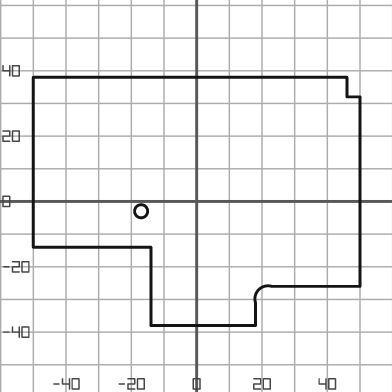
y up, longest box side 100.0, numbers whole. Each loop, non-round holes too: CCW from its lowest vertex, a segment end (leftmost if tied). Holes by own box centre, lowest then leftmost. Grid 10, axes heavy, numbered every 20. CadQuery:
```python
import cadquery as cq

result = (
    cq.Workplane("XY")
    .moveTo(-14.0, -38.0)
    .lineTo(18.0, -38.0)
    .lineTo(18.0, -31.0)
    .threePointArc((19.0, -27.0), (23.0, -26.0))
    .lineTo(50.0, -26.0)
    .lineTo(50.0, 32.0)
    .lineTo(46.0, 32.0)
    .lineTo(46.0, 38.0)
    .lineTo(-50.0, 38.0)
    .lineTo(-50.0, -14.0)
    .lineTo(-14.0, -14.0)
    .close()
    .moveTo(-17.0, -3.0)
    .circle(2.0)
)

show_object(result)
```